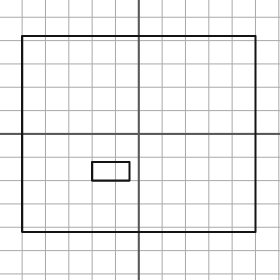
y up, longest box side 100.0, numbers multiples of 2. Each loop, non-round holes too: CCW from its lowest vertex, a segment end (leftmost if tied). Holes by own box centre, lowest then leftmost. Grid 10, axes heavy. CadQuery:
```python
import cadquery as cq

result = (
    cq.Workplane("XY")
    .moveTo(-50.0, -42.0)
    .lineTo(50.0, -42.0)
    .lineTo(50.0, 42.0)
    .lineTo(-50.0, 42.0)
    .close()
    .moveTo(-20.0, -20.0)
    .lineTo(-4.0, -20.0)
    .lineTo(-4.0, -12.0)
    .lineTo(-20.0, -12.0)
    .close()
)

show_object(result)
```